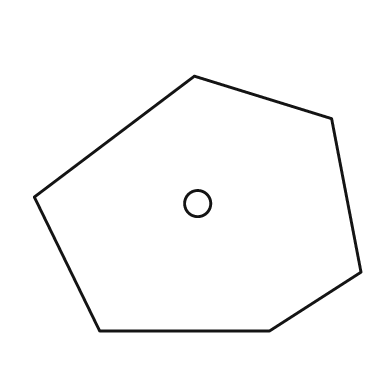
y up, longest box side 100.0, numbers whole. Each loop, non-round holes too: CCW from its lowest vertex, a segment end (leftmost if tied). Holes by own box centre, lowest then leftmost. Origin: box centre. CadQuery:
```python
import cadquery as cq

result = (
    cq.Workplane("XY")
    .moveTo(-30.0, -39.0)
    .lineTo(22.0, -39.0)
    .lineTo(50.0, -21.0)
    .lineTo(41.0, 26.0)
    .lineTo(-1.0, 39.0)
    .lineTo(-50.0, 2.0)
    .close()
    .moveTo(0.0, 0.0)
    .circle(4.0)
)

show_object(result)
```